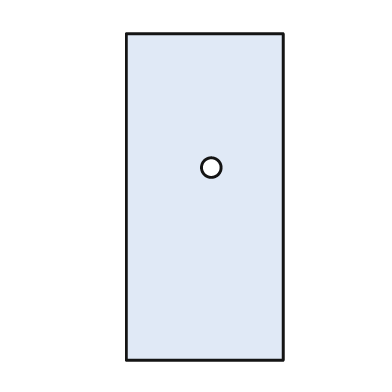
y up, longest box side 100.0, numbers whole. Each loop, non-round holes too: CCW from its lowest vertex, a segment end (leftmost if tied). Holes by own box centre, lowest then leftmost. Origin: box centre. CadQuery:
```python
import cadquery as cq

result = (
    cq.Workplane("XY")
    .moveTo(-24.0, -50.0)
    .lineTo(24.0, -50.0)
    .lineTo(24.0, 50.0)
    .lineTo(-24.0, 50.0)
    .close()
    .moveTo(2.0, 9.0)
    .circle(3.0)
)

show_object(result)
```